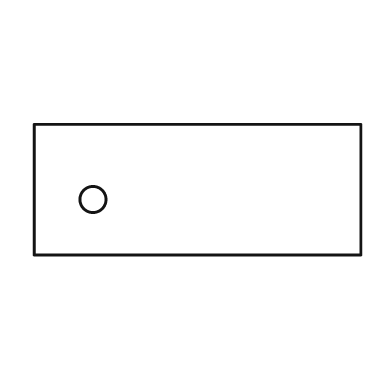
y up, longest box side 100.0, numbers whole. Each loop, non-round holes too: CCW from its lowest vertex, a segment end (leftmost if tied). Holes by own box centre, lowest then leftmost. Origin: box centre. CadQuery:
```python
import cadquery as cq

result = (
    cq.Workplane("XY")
    .moveTo(-50.0, -20.0)
    .lineTo(50.0, -20.0)
    .lineTo(50.0, 20.0)
    .lineTo(-50.0, 20.0)
    .close()
    .moveTo(-32.0, -3.0)
    .circle(4.0)
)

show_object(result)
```